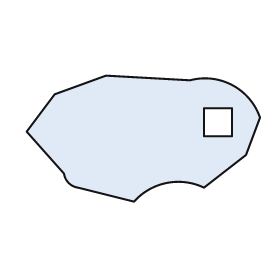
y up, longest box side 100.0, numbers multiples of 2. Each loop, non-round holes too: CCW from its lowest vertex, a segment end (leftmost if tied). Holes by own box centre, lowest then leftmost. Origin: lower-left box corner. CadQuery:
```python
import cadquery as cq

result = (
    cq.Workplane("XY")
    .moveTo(46.0, 0.0)
    .threePointArc((60.0, 8.0), (76.0, 6.0))
    .lineTo(94.0, 20.0)
    .lineTo(100.0, 36.0)
    .threePointArc((88.0, 50.0), (70.0, 52.0))
    .lineTo(34.0, 54.0)
    .lineTo(12.0, 46.0)
    .lineTo(0.0, 30.0)
    .lineTo(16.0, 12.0)
    .threePointArc((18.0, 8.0), (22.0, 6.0))
    .close()
    .moveTo(76.0, 28.0)
    .lineTo(88.0, 28.0)
    .lineTo(88.0, 40.0)
    .lineTo(76.0, 40.0)
    .close()
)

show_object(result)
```